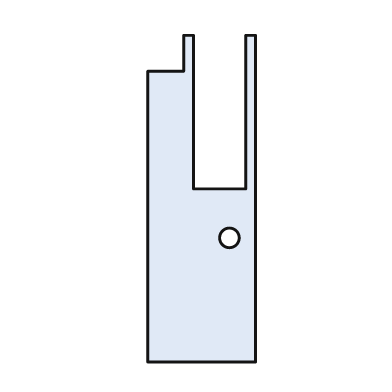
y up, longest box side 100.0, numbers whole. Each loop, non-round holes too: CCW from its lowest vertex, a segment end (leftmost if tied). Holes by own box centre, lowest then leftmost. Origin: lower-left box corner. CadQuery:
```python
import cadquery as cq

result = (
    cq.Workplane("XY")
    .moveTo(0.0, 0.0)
    .lineTo(33.0, 0.0)
    .lineTo(33.0, 100.0)
    .lineTo(30.0, 100.0)
    .lineTo(30.0, 53.0)
    .lineTo(14.0, 53.0)
    .lineTo(14.0, 100.0)
    .lineTo(11.0, 100.0)
    .lineTo(11.0, 89.0)
    .lineTo(0.0, 89.0)
    .close()
    .moveTo(25.0, 38.0)
    .circle(3.0)
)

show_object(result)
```